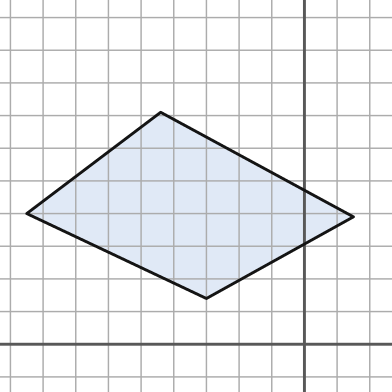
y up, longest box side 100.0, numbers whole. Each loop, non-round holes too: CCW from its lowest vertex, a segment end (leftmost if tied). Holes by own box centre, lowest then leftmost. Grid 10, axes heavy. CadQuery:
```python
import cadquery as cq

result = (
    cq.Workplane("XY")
    .moveTo(-30.0, 14.0)
    .lineTo(15.0, 39.0)
    .lineTo(-44.0, 71.0)
    .lineTo(-85.0, 40.0)
    .close()
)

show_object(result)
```